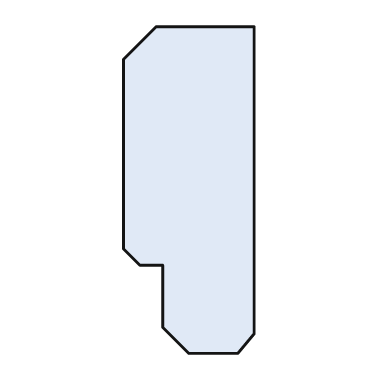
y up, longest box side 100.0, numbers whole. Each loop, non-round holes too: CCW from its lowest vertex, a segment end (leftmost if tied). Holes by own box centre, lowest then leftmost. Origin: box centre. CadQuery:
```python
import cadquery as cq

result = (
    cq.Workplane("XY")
    .moveTo(0.0, -50.0)
    .lineTo(15.0, -50.0)
    .lineTo(20.0, -44.0)
    .lineTo(20.0, 50.0)
    .lineTo(-10.0, 50.0)
    .lineTo(-20.0, 40.0)
    .lineTo(-20.0, -18.0)
    .lineTo(-15.0, -23.0)
    .lineTo(-8.0, -23.0)
    .lineTo(-8.0, -42.0)
    .close()
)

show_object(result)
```